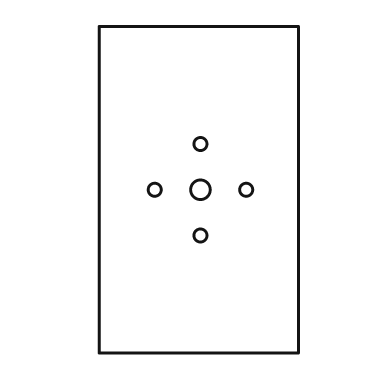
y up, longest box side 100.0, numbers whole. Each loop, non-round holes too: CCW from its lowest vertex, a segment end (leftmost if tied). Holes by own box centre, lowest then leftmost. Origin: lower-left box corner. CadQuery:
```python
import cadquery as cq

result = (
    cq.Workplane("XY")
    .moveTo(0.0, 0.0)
    .lineTo(61.0, 0.0)
    .lineTo(61.0, 100.0)
    .lineTo(0.0, 100.0)
    .close()
    .moveTo(31.0, 36.0)
    .circle(2.0)
    .moveTo(17.0, 50.0)
    .circle(2.0)
    .moveTo(31.0, 50.0)
    .circle(3.0)
    .moveTo(45.0, 50.0)
    .circle(2.0)
    .moveTo(31.0, 64.0)
    .circle(2.0)
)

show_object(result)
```